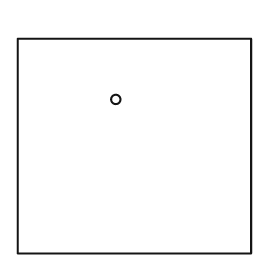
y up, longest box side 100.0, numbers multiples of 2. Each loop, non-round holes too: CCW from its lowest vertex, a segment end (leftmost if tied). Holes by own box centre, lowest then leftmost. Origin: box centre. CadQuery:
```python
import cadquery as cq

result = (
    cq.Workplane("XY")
    .moveTo(-50.0, -46.0)
    .lineTo(50.0, -46.0)
    .lineTo(50.0, 46.0)
    .lineTo(-50.0, 46.0)
    .close()
    .moveTo(-8.0, 20.0)
    .circle(2.0)
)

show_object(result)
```